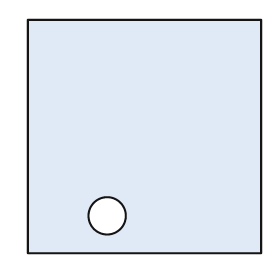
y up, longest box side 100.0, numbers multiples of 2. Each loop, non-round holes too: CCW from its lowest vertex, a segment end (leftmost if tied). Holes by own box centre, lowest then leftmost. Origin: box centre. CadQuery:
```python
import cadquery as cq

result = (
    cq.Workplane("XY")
    .moveTo(-50.0, -50.0)
    .lineTo(50.0, -50.0)
    .lineTo(50.0, 50.0)
    .lineTo(-50.0, 50.0)
    .close()
    .moveTo(-16.0, -34.0)
    .circle(8.0)
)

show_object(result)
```